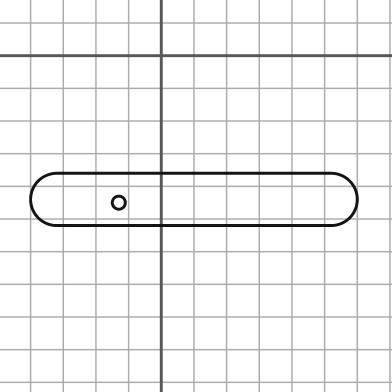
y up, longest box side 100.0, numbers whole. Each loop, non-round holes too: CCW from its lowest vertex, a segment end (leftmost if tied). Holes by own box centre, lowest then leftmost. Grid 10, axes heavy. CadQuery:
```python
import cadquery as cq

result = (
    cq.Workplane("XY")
    .moveTo(-32.0, -52.0)
    .lineTo(52.0, -52.0)
    .threePointArc((60.0, -44.0), (52.0, -36.0))
    .lineTo(-32.0, -36.0)
    .threePointArc((-40.0, -44.0), (-32.0, -52.0))
    .close()
    .moveTo(-13.0, -45.0)
    .circle(2.0)
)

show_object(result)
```